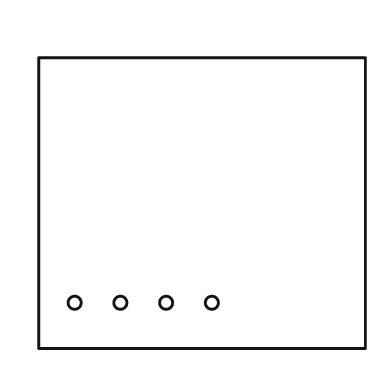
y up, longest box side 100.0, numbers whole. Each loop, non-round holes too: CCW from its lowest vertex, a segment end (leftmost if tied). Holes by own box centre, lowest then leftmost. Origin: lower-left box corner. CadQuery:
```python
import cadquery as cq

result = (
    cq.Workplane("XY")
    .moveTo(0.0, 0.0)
    .lineTo(100.0, 0.0)
    .lineTo(100.0, 89.0)
    .lineTo(0.0, 89.0)
    .close()
    .moveTo(11.0, 14.0)
    .circle(2.0)
    .moveTo(25.0, 14.0)
    .circle(2.0)
    .moveTo(39.0, 14.0)
    .circle(2.0)
    .moveTo(53.0, 14.0)
    .circle(2.0)
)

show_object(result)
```